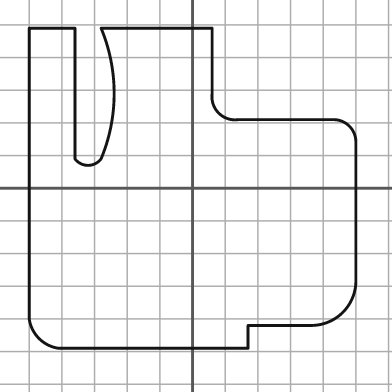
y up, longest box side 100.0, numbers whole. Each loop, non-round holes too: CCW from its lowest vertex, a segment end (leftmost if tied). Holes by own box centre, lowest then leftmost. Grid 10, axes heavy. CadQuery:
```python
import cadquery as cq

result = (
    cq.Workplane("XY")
    .moveTo(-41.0, -49.0)
    .lineTo(17.0, -49.0)
    .lineTo(17.0, -42.0)
    .lineTo(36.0, -42.0)
    .threePointArc((46.0, -38.0), (50.0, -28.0))
    .lineTo(50.0, 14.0)
    .threePointArc((48.0, 19.0), (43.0, 21.0))
    .lineTo(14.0, 21.0)
    .threePointArc((8.0, 23.0), (6.0, 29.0))
    .lineTo(6.0, 49.0)
    .lineTo(-28.0, 49.0)
    .threePointArc((-24.0, 29.0), (-28.0, 9.0))
    .threePointArc((-32.0, 7.0), (-36.0, 9.0))
    .lineTo(-36.0, 49.0)
    .lineTo(-50.0, 49.0)
    .lineTo(-50.0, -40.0)
    .threePointArc((-47.0, -46.0), (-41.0, -49.0))
    .close()
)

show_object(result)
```